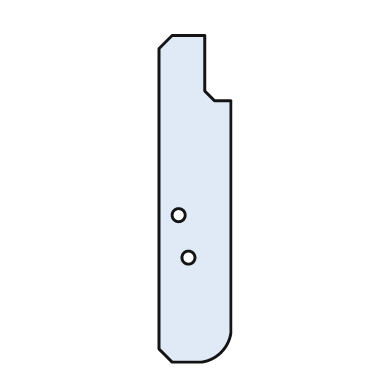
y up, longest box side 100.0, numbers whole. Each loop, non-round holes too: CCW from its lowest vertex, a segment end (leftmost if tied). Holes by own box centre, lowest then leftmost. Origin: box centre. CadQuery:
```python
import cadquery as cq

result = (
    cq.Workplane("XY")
    .moveTo(-7.0, -50.0)
    .lineTo(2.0, -50.0)
    .threePointArc((8.0, -47.0), (11.0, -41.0))
    .lineTo(11.0, 30.0)
    .lineTo(6.0, 30.0)
    .lineTo(3.0, 33.0)
    .lineTo(3.0, 50.0)
    .lineTo(-7.0, 50.0)
    .lineTo(-11.0, 46.0)
    .lineTo(-11.0, -46.0)
    .close()
    .moveTo(-2.0, -18.0)
    .circle(2.0)
    .moveTo(-5.0, -5.0)
    .circle(2.0)
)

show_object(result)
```